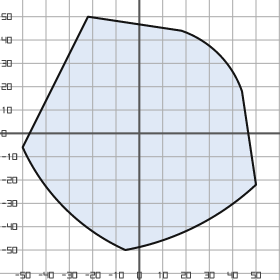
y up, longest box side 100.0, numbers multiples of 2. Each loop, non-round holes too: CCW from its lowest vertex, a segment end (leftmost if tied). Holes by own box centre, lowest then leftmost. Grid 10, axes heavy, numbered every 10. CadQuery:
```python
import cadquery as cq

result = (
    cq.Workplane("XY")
    .moveTo(-6.0, -50.0)
    .threePointArc((24.0, -40.0), (50.0, -22.0))
    .lineTo(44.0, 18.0)
    .threePointArc((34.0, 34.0), (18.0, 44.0))
    .lineTo(-22.0, 50.0)
    .lineTo(-50.0, -6.0)
    .threePointArc((-32.0, -32.0), (-6.0, -50.0))
    .close()
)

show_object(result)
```